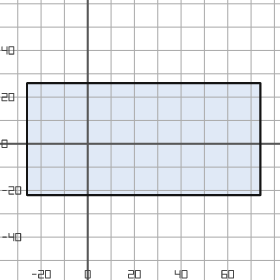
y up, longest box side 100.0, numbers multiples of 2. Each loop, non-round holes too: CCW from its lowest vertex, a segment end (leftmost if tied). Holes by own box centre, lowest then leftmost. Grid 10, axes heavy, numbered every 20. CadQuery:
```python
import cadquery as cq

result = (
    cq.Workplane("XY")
    .moveTo(-26.0, -22.0)
    .lineTo(74.0, -22.0)
    .lineTo(74.0, 26.0)
    .lineTo(-26.0, 26.0)
    .close()
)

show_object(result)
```